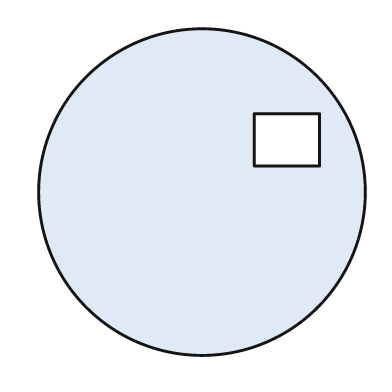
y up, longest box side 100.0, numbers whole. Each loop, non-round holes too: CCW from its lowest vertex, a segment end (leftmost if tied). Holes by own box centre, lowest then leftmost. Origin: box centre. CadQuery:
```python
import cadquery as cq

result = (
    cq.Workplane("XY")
    .moveTo(0.0, 0.0)
    .circle(50.0)
    .moveTo(16.0, 8.0)
    .lineTo(36.0, 8.0)
    .lineTo(36.0, 24.0)
    .lineTo(16.0, 24.0)
    .close()
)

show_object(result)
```